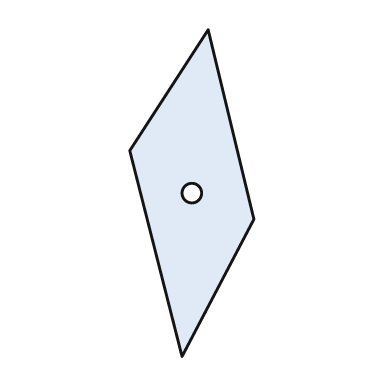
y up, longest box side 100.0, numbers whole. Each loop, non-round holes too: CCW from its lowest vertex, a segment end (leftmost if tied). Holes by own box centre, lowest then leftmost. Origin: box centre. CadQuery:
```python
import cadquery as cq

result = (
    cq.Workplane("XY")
    .moveTo(-3.0, -50.0)
    .lineTo(19.0, -8.0)
    .lineTo(5.0, 50.0)
    .lineTo(-19.0, 13.0)
    .close()
    .moveTo(0.0, 0.0)
    .circle(3.0)
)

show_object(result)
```